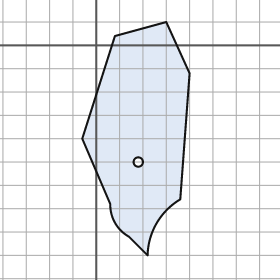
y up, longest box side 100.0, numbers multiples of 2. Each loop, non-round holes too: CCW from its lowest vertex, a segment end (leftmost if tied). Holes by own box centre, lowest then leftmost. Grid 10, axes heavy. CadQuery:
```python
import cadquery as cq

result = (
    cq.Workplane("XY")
    .moveTo(22.0, -90.0)
    .threePointArc((26.0, -76.0), (36.0, -66.0))
    .lineTo(40.0, -12.0)
    .lineTo(30.0, 10.0)
    .lineTo(8.0, 4.0)
    .lineTo(-6.0, -40.0)
    .lineTo(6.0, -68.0)
    .threePointArc((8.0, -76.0), (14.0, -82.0))
    .close()
    .moveTo(18.0, -50.0)
    .circle(2.0)
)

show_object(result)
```